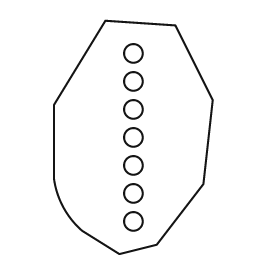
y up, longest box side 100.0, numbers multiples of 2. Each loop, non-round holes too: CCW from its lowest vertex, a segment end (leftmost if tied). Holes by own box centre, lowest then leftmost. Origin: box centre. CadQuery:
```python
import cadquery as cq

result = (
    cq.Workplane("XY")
    .moveTo(-6.0, -50.0)
    .lineTo(10.0, -46.0)
    .lineTo(30.0, -20.0)
    .lineTo(34.0, 16.0)
    .lineTo(18.0, 48.0)
    .lineTo(-12.0, 50.0)
    .lineTo(-34.0, 14.0)
    .lineTo(-34.0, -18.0)
    .threePointArc((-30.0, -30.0), (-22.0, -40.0))
    .close()
    .moveTo(0.0, -36.0)
    .circle(4.0)
    .moveTo(0.0, -24.0)
    .circle(4.0)
    .moveTo(0.0, -12.0)
    .circle(4.0)
    .moveTo(0.0, 0.0)
    .circle(4.0)
    .moveTo(0.0, 12.0)
    .circle(4.0)
    .moveTo(0.0, 24.0)
    .circle(4.0)
    .moveTo(0.0, 36.0)
    .circle(4.0)
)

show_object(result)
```